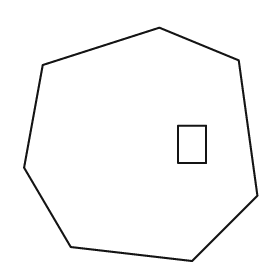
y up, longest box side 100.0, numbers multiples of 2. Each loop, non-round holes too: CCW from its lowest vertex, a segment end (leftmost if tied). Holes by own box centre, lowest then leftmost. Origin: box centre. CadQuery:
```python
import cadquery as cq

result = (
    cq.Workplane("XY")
    .moveTo(22.0, -50.0)
    .lineTo(50.0, -22.0)
    .lineTo(42.0, 36.0)
    .lineTo(8.0, 50.0)
    .lineTo(-42.0, 34.0)
    .lineTo(-50.0, -10.0)
    .lineTo(-30.0, -44.0)
    .close()
    .moveTo(16.0, -8.0)
    .lineTo(28.0, -8.0)
    .lineTo(28.0, 8.0)
    .lineTo(16.0, 8.0)
    .close()
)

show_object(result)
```